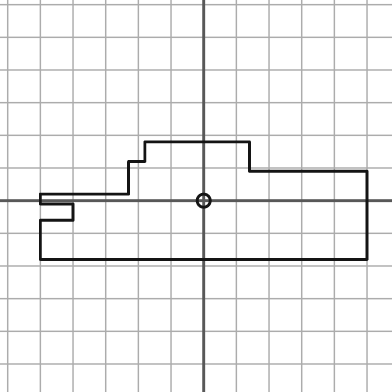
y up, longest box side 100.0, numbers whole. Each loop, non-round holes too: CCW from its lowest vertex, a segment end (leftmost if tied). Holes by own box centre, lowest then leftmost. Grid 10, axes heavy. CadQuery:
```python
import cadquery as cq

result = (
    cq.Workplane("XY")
    .moveTo(-50.0, -18.0)
    .lineTo(50.0, -18.0)
    .lineTo(50.0, 9.0)
    .lineTo(14.0, 9.0)
    .lineTo(14.0, 18.0)
    .lineTo(-18.0, 18.0)
    .lineTo(-18.0, 12.0)
    .lineTo(-23.0, 12.0)
    .lineTo(-23.0, 2.0)
    .lineTo(-50.0, 2.0)
    .lineTo(-50.0, -1.0)
    .lineTo(-40.0, -1.0)
    .lineTo(-40.0, -6.0)
    .lineTo(-50.0, -6.0)
    .close()
    .moveTo(0.0, 0.0)
    .circle(2.0)
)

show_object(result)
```